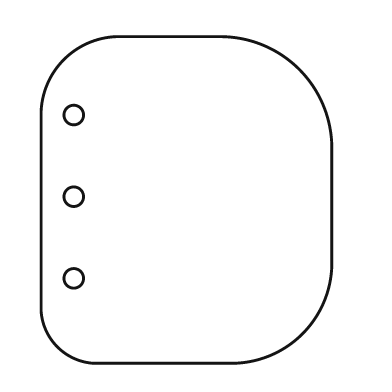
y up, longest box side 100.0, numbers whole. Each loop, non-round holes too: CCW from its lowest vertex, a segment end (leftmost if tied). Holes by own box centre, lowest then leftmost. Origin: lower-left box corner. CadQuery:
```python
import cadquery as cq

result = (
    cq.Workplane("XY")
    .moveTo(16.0, 0.0)
    .lineTo(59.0, 0.0)
    .threePointArc((80.0, 9.0), (89.0, 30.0))
    .lineTo(89.0, 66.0)
    .threePointArc((79.0, 90.0), (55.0, 100.0))
    .lineTo(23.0, 100.0)
    .threePointArc((7.0, 93.0), (0.0, 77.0))
    .lineTo(0.0, 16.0)
    .threePointArc((5.0, 5.0), (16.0, 0.0))
    .close()
    .moveTo(10.0, 26.0)
    .circle(3.0)
    .moveTo(10.0, 51.0)
    .circle(3.0)
    .moveTo(10.0, 76.0)
    .circle(3.0)
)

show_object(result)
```